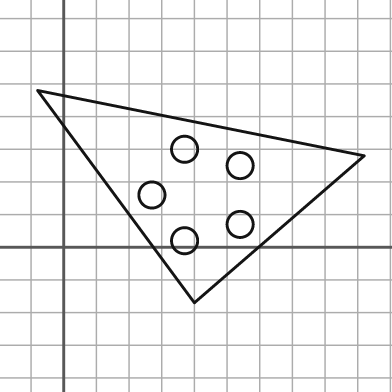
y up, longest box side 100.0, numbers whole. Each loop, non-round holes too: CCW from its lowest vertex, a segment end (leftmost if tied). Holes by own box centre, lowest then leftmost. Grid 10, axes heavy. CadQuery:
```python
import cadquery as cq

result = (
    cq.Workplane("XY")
    .moveTo(40.0, -17.0)
    .lineTo(92.0, 28.0)
    .lineTo(-8.0, 48.0)
    .close()
    .moveTo(37.0, 2.0)
    .circle(4.0)
    .moveTo(54.0, 7.0)
    .circle(4.0)
    .moveTo(27.0, 16.0)
    .circle(4.0)
    .moveTo(54.0, 25.0)
    .circle(4.0)
    .moveTo(37.0, 30.0)
    .circle(4.0)
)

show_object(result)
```